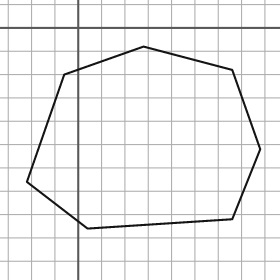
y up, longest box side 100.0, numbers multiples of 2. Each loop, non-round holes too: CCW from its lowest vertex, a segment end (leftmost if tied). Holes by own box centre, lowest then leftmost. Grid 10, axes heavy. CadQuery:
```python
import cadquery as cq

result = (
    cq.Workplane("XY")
    .moveTo(4.0, -86.0)
    .lineTo(66.0, -82.0)
    .lineTo(78.0, -52.0)
    .lineTo(66.0, -18.0)
    .lineTo(28.0, -8.0)
    .lineTo(-6.0, -20.0)
    .lineTo(-22.0, -66.0)
    .close()
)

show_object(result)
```